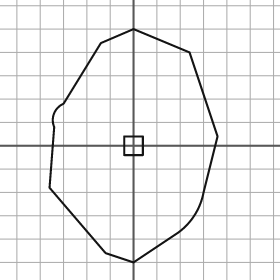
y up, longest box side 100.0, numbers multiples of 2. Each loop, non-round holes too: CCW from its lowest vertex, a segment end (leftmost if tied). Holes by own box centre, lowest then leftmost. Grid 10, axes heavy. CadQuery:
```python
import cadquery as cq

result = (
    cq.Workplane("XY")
    .moveTo(0.0, -50.0)
    .lineTo(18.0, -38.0)
    .threePointArc((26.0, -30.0), (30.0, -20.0))
    .lineTo(36.0, 4.0)
    .lineTo(24.0, 40.0)
    .lineTo(0.0, 50.0)
    .lineTo(-14.0, 44.0)
    .lineTo(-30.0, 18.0)
    .threePointArc((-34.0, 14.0), (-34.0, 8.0))
    .lineTo(-36.0, -18.0)
    .lineTo(-12.0, -46.0)
    .close()
    .moveTo(-4.0, -4.0)
    .lineTo(4.0, -4.0)
    .lineTo(4.0, 4.0)
    .lineTo(-4.0, 4.0)
    .close()
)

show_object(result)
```